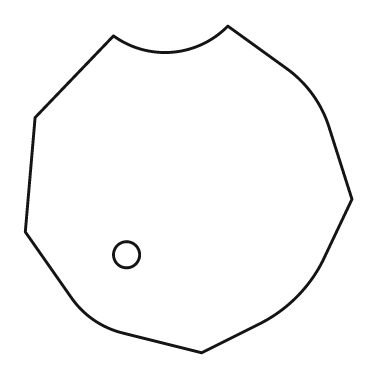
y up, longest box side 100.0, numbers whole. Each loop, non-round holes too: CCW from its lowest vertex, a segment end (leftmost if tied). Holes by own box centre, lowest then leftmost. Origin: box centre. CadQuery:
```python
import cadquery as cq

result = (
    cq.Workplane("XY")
    .moveTo(4.0, -50.0)
    .lineTo(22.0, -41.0)
    .threePointArc((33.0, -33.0), (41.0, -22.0))
    .lineTo(50.0, -3.0)
    .lineTo(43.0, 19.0)
    .threePointArc((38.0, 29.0), (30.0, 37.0))
    .lineTo(12.0, 50.0)
    .threePointArc((-5.0, 42.0), (-23.0, 47.0))
    .lineTo(-47.0, 22.0)
    .lineTo(-50.0, -13.0)
    .lineTo(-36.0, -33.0)
    .threePointArc((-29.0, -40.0), (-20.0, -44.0))
    .close()
    .moveTo(-19.0, -20.0)
    .circle(4.0)
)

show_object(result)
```